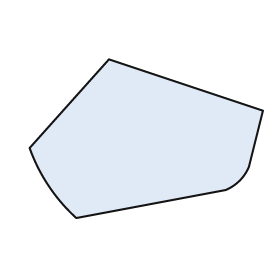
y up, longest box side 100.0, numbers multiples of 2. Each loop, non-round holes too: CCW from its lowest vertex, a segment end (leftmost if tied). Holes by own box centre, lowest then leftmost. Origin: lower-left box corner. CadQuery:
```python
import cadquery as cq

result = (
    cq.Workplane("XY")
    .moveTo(20.0, 0.0)
    .lineTo(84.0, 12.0)
    .threePointArc((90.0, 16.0), (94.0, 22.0))
    .lineTo(100.0, 46.0)
    .lineTo(34.0, 68.0)
    .lineTo(0.0, 30.0)
    .threePointArc((8.0, 14.0), (20.0, 0.0))
    .close()
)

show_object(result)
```